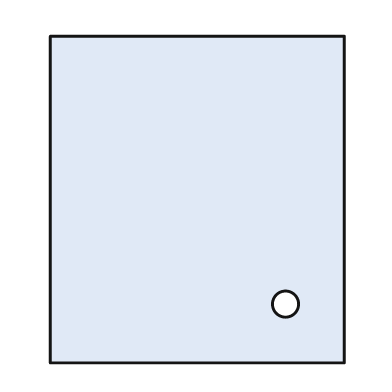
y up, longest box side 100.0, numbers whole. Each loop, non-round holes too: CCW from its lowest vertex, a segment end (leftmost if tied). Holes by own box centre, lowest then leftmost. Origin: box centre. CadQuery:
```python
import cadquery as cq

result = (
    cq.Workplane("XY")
    .moveTo(-45.0, -50.0)
    .lineTo(45.0, -50.0)
    .lineTo(45.0, 50.0)
    .lineTo(-45.0, 50.0)
    .close()
    .moveTo(27.0, -32.0)
    .circle(4.0)
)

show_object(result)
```